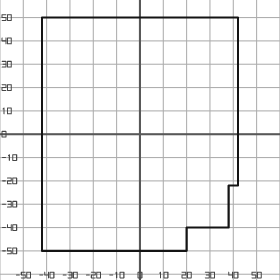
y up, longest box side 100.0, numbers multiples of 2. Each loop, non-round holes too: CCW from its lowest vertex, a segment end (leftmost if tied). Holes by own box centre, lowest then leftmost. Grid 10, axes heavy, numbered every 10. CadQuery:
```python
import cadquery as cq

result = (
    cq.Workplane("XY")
    .moveTo(-42.0, -50.0)
    .lineTo(20.0, -50.0)
    .lineTo(20.0, -40.0)
    .lineTo(38.0, -40.0)
    .lineTo(38.0, -22.0)
    .lineTo(42.0, -22.0)
    .lineTo(42.0, 50.0)
    .lineTo(-42.0, 50.0)
    .close()
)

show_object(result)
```